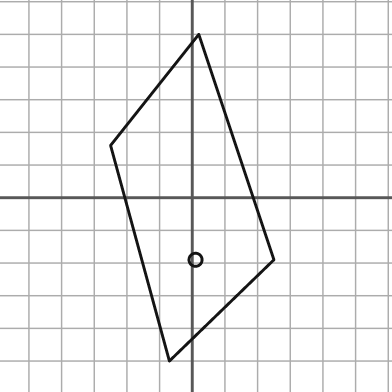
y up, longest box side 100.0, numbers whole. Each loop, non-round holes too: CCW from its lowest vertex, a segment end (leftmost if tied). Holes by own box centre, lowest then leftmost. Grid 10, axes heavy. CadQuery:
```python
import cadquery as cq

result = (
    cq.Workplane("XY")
    .moveTo(-7.0, -50.0)
    .lineTo(25.0, -19.0)
    .lineTo(2.0, 50.0)
    .lineTo(-25.0, 16.0)
    .close()
    .moveTo(1.0, -19.0)
    .circle(2.0)
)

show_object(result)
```